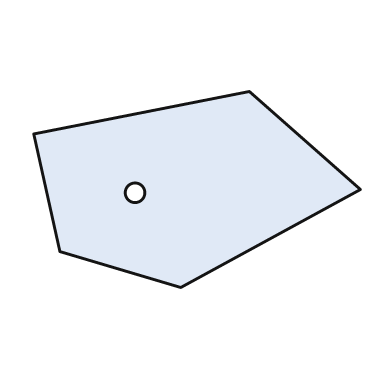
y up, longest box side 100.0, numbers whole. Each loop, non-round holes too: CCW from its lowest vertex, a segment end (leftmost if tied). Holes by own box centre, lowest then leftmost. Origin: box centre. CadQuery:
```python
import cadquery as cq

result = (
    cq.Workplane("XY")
    .moveTo(-5.0, -30.0)
    .lineTo(50.0, 0.0)
    .lineTo(16.0, 30.0)
    .lineTo(-50.0, 17.0)
    .lineTo(-42.0, -19.0)
    .close()
    .moveTo(-19.0, -1.0)
    .circle(3.0)
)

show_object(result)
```